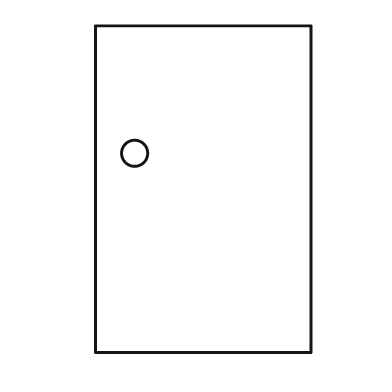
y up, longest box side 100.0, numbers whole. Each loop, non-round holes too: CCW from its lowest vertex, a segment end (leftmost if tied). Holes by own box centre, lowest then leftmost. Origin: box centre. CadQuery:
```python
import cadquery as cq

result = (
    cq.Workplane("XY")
    .moveTo(-33.0, -50.0)
    .lineTo(33.0, -50.0)
    .lineTo(33.0, 50.0)
    .lineTo(-33.0, 50.0)
    .close()
    .moveTo(-21.0, 11.0)
    .circle(4.0)
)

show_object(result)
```